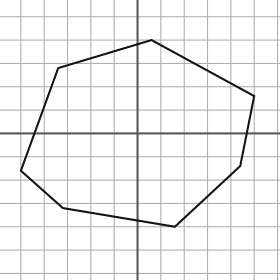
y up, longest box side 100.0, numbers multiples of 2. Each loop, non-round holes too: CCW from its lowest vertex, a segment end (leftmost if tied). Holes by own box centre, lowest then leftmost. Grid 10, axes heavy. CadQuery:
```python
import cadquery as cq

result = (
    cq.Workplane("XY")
    .moveTo(16.0, -40.0)
    .lineTo(44.0, -14.0)
    .lineTo(50.0, 16.0)
    .lineTo(6.0, 40.0)
    .lineTo(-34.0, 28.0)
    .lineTo(-50.0, -16.0)
    .lineTo(-32.0, -32.0)
    .close()
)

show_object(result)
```